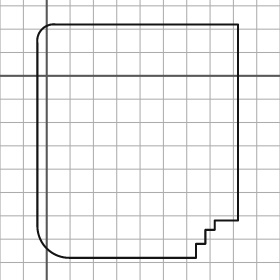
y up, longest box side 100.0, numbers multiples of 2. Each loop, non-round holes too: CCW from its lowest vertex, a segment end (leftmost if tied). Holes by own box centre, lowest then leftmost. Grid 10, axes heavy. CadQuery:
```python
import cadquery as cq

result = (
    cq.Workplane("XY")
    .moveTo(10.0, -78.0)
    .lineTo(64.0, -78.0)
    .lineTo(64.0, -72.0)
    .lineTo(68.0, -72.0)
    .lineTo(68.0, -66.0)
    .lineTo(72.0, -66.0)
    .lineTo(72.0, -62.0)
    .lineTo(82.0, -62.0)
    .lineTo(82.0, 22.0)
    .lineTo(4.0, 22.0)
    .threePointArc((-2.0, 20.0), (-4.0, 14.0))
    .lineTo(-4.0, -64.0)
    .threePointArc((0.0, -74.0), (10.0, -78.0))
    .close()
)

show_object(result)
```